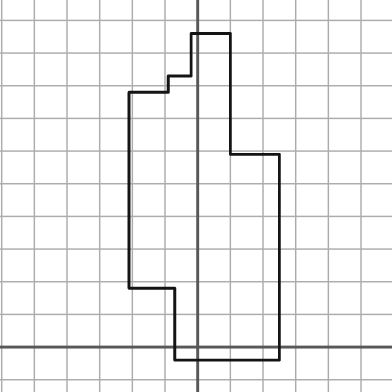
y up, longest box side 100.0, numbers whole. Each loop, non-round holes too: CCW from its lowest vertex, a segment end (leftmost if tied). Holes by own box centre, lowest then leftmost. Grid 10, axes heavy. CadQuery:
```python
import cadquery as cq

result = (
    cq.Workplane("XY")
    .moveTo(-7.0, -4.0)
    .lineTo(25.0, -4.0)
    .lineTo(25.0, 59.0)
    .lineTo(10.0, 59.0)
    .lineTo(10.0, 96.0)
    .lineTo(-2.0, 96.0)
    .lineTo(-2.0, 83.0)
    .lineTo(-9.0, 83.0)
    .lineTo(-9.0, 78.0)
    .lineTo(-21.0, 78.0)
    .lineTo(-21.0, 18.0)
    .lineTo(-7.0, 18.0)
    .close()
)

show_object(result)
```